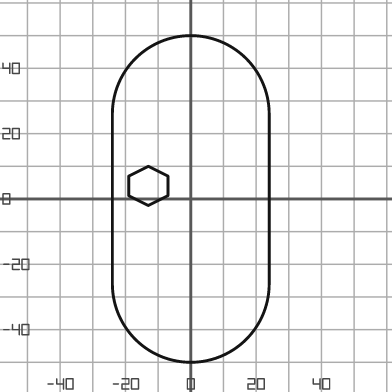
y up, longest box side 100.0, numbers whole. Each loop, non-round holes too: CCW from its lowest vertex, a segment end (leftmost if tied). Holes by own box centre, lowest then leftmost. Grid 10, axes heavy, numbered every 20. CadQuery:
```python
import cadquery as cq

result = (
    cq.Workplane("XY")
    .moveTo(-24.0, -26.0)
    .threePointArc((0.0, -50.0), (24.0, -26.0))
    .lineTo(24.0, 26.0)
    .threePointArc((0.0, 50.0), (-24.0, 26.0))
    .close()
    .moveTo(-13.0, -2.0)
    .lineTo(-7.0, 1.0)
    .lineTo(-7.0, 7.0)
    .lineTo(-13.0, 10.0)
    .lineTo(-19.0, 7.0)
    .lineTo(-19.0, 1.0)
    .close()
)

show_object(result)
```